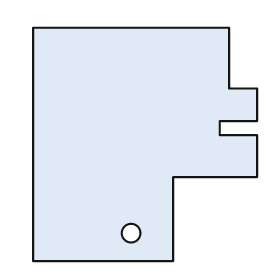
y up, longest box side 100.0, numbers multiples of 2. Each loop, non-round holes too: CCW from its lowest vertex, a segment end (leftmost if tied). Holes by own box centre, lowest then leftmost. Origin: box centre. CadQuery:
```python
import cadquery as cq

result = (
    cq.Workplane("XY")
    .moveTo(-48.0, -50.0)
    .lineTo(12.0, -50.0)
    .lineTo(12.0, -14.0)
    .lineTo(48.0, -14.0)
    .lineTo(48.0, 4.0)
    .lineTo(32.0, 4.0)
    .lineTo(32.0, 10.0)
    .lineTo(48.0, 10.0)
    .lineTo(48.0, 24.0)
    .lineTo(36.0, 24.0)
    .lineTo(36.0, 50.0)
    .lineTo(-48.0, 50.0)
    .close()
    .moveTo(-6.0, -38.0)
    .circle(4.0)
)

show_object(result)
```